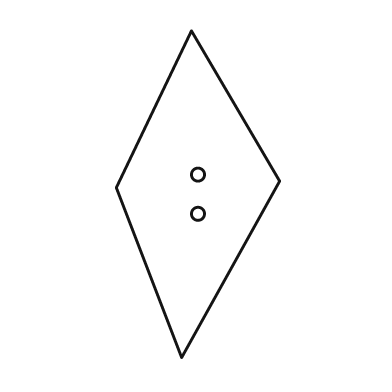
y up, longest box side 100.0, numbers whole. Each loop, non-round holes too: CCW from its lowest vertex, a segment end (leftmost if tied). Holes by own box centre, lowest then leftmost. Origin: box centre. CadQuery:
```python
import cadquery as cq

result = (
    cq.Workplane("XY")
    .moveTo(-5.0, -50.0)
    .lineTo(25.0, 4.0)
    .lineTo(-2.0, 50.0)
    .lineTo(-25.0, 2.0)
    .close()
    .moveTo(0.0, -6.0)
    .circle(2.0)
    .moveTo(0.0, 6.0)
    .circle(2.0)
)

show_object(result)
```